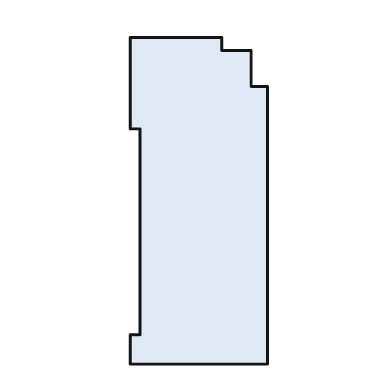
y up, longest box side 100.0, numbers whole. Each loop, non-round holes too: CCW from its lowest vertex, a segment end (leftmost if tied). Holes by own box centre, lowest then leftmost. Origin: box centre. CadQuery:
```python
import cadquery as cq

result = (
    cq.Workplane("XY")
    .moveTo(-21.0, -50.0)
    .lineTo(21.0, -50.0)
    .lineTo(21.0, 35.0)
    .lineTo(16.0, 35.0)
    .lineTo(16.0, 46.0)
    .lineTo(7.0, 46.0)
    .lineTo(7.0, 50.0)
    .lineTo(-21.0, 50.0)
    .lineTo(-21.0, 22.0)
    .lineTo(-18.0, 22.0)
    .lineTo(-18.0, -41.0)
    .lineTo(-21.0, -41.0)
    .close()
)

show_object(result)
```